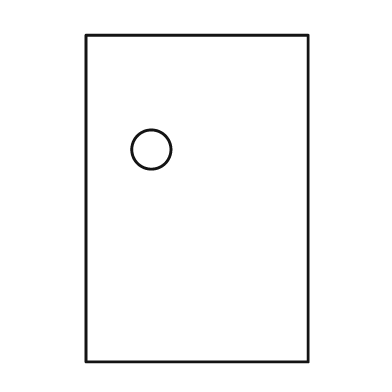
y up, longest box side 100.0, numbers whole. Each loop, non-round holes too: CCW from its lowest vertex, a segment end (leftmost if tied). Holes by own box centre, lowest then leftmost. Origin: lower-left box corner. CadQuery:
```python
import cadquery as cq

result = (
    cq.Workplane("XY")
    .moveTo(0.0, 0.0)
    .lineTo(68.0, 0.0)
    .lineTo(68.0, 100.0)
    .lineTo(0.0, 100.0)
    .close()
    .moveTo(20.0, 65.0)
    .circle(6.0)
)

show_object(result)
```